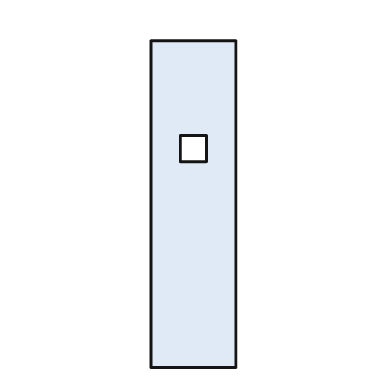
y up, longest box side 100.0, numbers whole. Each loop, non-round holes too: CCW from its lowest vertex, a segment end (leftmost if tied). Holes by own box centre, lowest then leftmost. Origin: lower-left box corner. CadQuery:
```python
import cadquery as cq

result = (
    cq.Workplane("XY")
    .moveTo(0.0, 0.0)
    .lineTo(26.0, 0.0)
    .lineTo(26.0, 100.0)
    .lineTo(0.0, 100.0)
    .close()
    .moveTo(9.0, 63.0)
    .lineTo(17.0, 63.0)
    .lineTo(17.0, 71.0)
    .lineTo(9.0, 71.0)
    .close()
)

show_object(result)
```